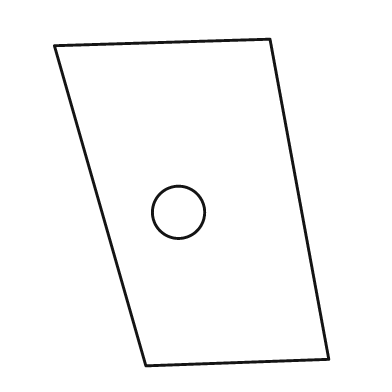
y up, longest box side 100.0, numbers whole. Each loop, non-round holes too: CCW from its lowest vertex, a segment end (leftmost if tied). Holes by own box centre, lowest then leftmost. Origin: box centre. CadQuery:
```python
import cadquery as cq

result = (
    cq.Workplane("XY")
    .moveTo(-14.0, -50.0)
    .lineTo(42.0, -48.0)
    .lineTo(24.0, 50.0)
    .lineTo(-42.0, 48.0)
    .close()
    .moveTo(-4.0, -3.0)
    .circle(8.0)
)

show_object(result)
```